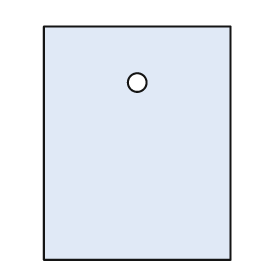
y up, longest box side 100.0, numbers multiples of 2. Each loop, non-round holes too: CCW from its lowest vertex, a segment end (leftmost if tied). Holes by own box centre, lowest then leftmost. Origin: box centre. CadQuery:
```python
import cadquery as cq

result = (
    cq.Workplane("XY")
    .moveTo(-40.0, -50.0)
    .lineTo(40.0, -50.0)
    .lineTo(40.0, 50.0)
    .lineTo(-40.0, 50.0)
    .close()
    .moveTo(0.0, 26.0)
    .circle(4.0)
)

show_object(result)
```